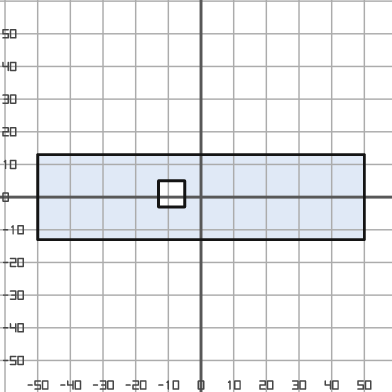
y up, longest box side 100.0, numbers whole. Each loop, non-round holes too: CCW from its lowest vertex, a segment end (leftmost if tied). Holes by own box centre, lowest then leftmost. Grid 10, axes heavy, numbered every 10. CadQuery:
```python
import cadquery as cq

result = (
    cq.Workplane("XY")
    .moveTo(-50.0, -13.0)
    .lineTo(50.0, -13.0)
    .lineTo(50.0, 13.0)
    .lineTo(-50.0, 13.0)
    .close()
    .moveTo(-13.0, -3.0)
    .lineTo(-5.0, -3.0)
    .lineTo(-5.0, 5.0)
    .lineTo(-13.0, 5.0)
    .close()
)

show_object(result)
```